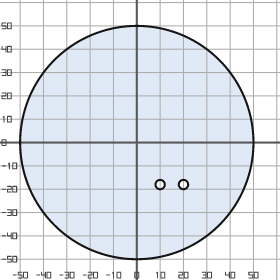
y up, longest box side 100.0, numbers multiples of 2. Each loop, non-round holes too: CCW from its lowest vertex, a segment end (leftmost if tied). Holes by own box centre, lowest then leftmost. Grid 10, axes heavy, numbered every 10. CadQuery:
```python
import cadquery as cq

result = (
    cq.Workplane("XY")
    .moveTo(0.0, 0.0)
    .circle(50.0)
    .moveTo(10.0, -18.0)
    .circle(2.0)
    .moveTo(20.0, -18.0)
    .circle(2.0)
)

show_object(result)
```